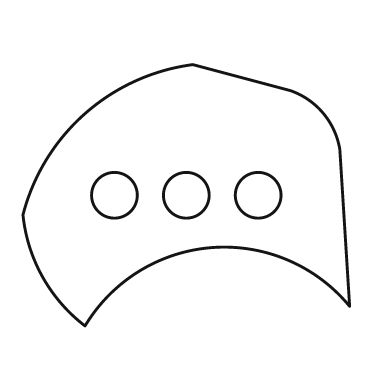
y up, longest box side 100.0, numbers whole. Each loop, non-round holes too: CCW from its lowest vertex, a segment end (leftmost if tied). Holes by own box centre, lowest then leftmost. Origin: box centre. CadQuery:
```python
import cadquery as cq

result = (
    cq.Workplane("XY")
    .moveTo(-31.0, -40.0)
    .threePointArc((8.0, -16.0), (50.0, -34.0))
    .lineTo(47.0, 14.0)
    .threePointArc((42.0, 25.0), (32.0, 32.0))
    .lineTo(2.0, 40.0)
    .threePointArc((-31.0, 25.0), (-50.0, -6.0))
    .threePointArc((-44.0, -25.0), (-31.0, -40.0))
    .close()
    .moveTo(-22.0, 0.0)
    .circle(7.0)
    .moveTo(0.0, 0.0)
    .circle(7.0)
    .moveTo(22.0, 0.0)
    .circle(7.0)
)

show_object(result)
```